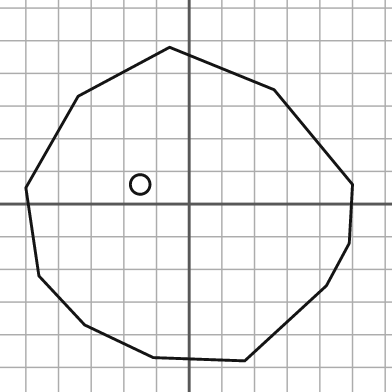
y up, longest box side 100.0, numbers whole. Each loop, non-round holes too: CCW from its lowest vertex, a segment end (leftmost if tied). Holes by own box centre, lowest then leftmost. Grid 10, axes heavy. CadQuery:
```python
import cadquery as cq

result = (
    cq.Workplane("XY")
    .moveTo(17.0, -48.0)
    .lineTo(42.0, -25.0)
    .lineTo(49.0, -12.0)
    .lineTo(50.0, 6.0)
    .lineTo(26.0, 35.0)
    .lineTo(-6.0, 48.0)
    .lineTo(-34.0, 33.0)
    .lineTo(-50.0, 5.0)
    .lineTo(-46.0, -22.0)
    .lineTo(-32.0, -37.0)
    .lineTo(-11.0, -47.0)
    .close()
    .moveTo(-15.0, 6.0)
    .circle(3.0)
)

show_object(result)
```